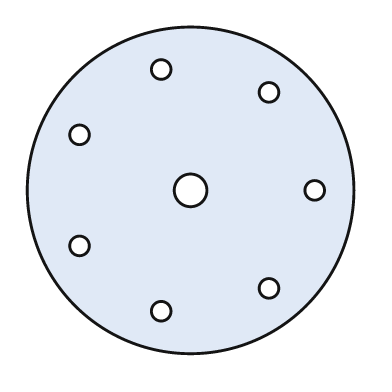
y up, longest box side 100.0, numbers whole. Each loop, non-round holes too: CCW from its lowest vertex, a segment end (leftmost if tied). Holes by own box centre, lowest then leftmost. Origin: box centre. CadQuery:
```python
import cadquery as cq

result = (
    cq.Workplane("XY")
    .moveTo(0.0, 0.0)
    .circle(50.0)
    .moveTo(-9.0, -37.0)
    .circle(3.0)
    .moveTo(24.0, -30.0)
    .circle(3.0)
    .moveTo(-34.0, -17.0)
    .circle(3.0)
    .moveTo(0.0, 0.0)
    .circle(5.0)
    .moveTo(38.0, 0.0)
    .circle(3.0)
    .moveTo(-34.0, 17.0)
    .circle(3.0)
    .moveTo(24.0, 30.0)
    .circle(3.0)
    .moveTo(-9.0, 37.0)
    .circle(3.0)
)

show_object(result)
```